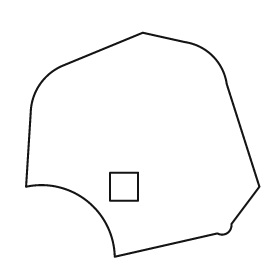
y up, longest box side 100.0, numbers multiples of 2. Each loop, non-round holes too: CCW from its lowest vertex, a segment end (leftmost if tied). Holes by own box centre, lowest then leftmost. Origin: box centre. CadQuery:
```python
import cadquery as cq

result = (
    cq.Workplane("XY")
    .moveTo(-12.0, -48.0)
    .lineTo(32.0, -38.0)
    .threePointArc((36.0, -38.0), (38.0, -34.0))
    .lineTo(50.0, -18.0)
    .lineTo(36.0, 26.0)
    .threePointArc((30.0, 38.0), (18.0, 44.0))
    .lineTo(0.0, 48.0)
    .lineTo(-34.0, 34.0)
    .threePointArc((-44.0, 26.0), (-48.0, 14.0))
    .lineTo(-50.0, -18.0)
    .threePointArc((-24.0, -24.0), (-12.0, -48.0))
    .close()
    .moveTo(-14.0, -24.0)
    .lineTo(-2.0, -24.0)
    .lineTo(-2.0, -12.0)
    .lineTo(-14.0, -12.0)
    .close()
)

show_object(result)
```